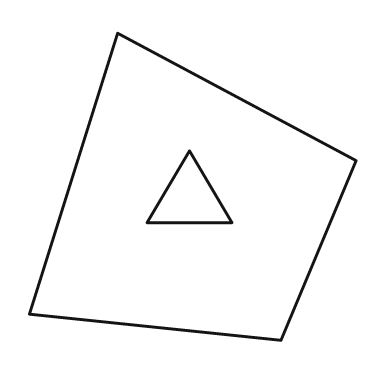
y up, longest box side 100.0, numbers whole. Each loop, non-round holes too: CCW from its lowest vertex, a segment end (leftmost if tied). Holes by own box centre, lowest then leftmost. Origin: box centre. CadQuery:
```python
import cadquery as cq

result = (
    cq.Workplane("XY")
    .moveTo(27.0, -47.0)
    .lineTo(50.0, 8.0)
    .lineTo(-23.0, 47.0)
    .lineTo(-50.0, -39.0)
    .close()
    .moveTo(-14.0, -11.0)
    .lineTo(12.0, -11.0)
    .lineTo(-1.0, 11.0)
    .close()
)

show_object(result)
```